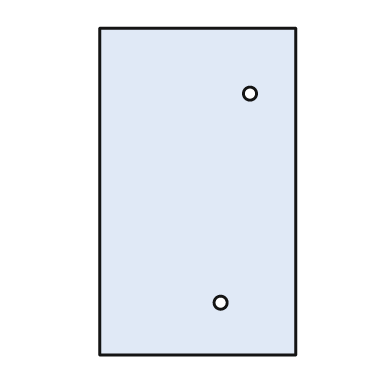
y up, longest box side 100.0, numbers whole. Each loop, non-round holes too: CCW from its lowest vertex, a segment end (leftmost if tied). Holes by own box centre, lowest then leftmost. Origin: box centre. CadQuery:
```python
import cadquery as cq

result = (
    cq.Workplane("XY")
    .moveTo(-30.0, -50.0)
    .lineTo(30.0, -50.0)
    .lineTo(30.0, 50.0)
    .lineTo(-30.0, 50.0)
    .close()
    .moveTo(7.0, -34.0)
    .circle(2.0)
    .moveTo(16.0, 30.0)
    .circle(2.0)
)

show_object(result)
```